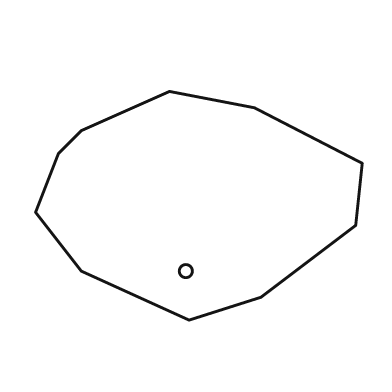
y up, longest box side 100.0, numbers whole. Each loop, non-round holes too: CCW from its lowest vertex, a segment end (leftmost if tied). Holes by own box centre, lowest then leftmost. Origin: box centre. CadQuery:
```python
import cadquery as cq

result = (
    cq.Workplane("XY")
    .moveTo(-3.0, -35.0)
    .lineTo(19.0, -28.0)
    .lineTo(48.0, -6.0)
    .lineTo(50.0, 13.0)
    .lineTo(17.0, 30.0)
    .lineTo(-9.0, 35.0)
    .lineTo(-36.0, 23.0)
    .lineTo(-43.0, 16.0)
    .lineTo(-50.0, -2.0)
    .lineTo(-36.0, -20.0)
    .close()
    .moveTo(-4.0, -20.0)
    .circle(2.0)
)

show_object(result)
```